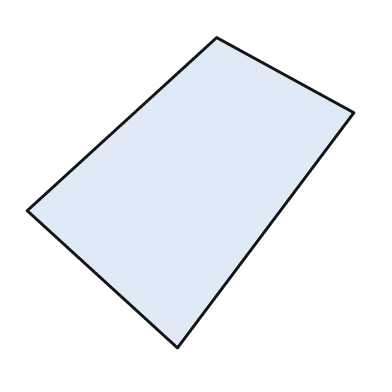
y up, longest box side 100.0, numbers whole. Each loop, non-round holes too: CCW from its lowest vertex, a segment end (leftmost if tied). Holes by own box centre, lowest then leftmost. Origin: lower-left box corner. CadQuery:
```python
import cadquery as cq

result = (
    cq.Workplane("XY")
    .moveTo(46.0, 0.0)
    .lineTo(100.0, 72.0)
    .lineTo(58.0, 95.0)
    .lineTo(0.0, 42.0)
    .close()
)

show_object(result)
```